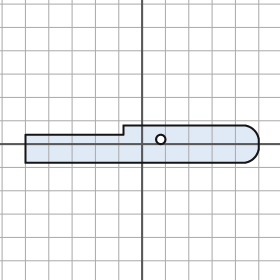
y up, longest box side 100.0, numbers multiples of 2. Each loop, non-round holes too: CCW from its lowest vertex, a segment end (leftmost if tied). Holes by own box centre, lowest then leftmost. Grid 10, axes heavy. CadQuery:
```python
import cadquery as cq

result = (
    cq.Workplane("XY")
    .moveTo(-50.0, -8.0)
    .lineTo(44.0, -8.0)
    .threePointArc((48.0, -6.0), (50.0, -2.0))
    .lineTo(50.0, 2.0)
    .threePointArc((48.0, 6.0), (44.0, 8.0))
    .lineTo(-8.0, 8.0)
    .lineTo(-8.0, 4.0)
    .lineTo(-50.0, 4.0)
    .close()
    .moveTo(8.0, 2.0)
    .circle(2.0)
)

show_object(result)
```